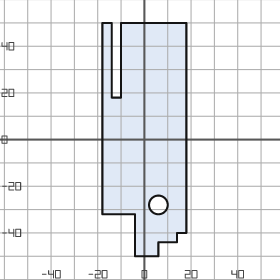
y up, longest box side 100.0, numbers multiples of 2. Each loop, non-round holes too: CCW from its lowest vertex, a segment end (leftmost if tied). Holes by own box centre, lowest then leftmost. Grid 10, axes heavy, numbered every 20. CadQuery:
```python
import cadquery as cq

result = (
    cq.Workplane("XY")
    .moveTo(-4.0, -50.0)
    .lineTo(6.0, -50.0)
    .lineTo(6.0, -44.0)
    .lineTo(14.0, -44.0)
    .lineTo(14.0, -40.0)
    .lineTo(18.0, -40.0)
    .lineTo(18.0, 50.0)
    .lineTo(-10.0, 50.0)
    .lineTo(-10.0, 18.0)
    .lineTo(-14.0, 18.0)
    .lineTo(-14.0, 50.0)
    .lineTo(-18.0, 50.0)
    .lineTo(-18.0, -32.0)
    .lineTo(-4.0, -32.0)
    .close()
    .moveTo(6.0, -28.0)
    .circle(4.0)
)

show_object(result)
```